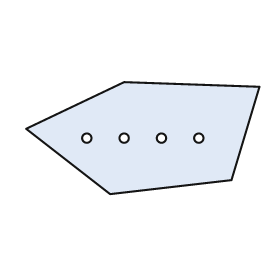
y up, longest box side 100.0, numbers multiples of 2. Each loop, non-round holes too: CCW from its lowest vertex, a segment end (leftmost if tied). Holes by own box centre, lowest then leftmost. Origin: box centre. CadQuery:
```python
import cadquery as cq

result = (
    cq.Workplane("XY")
    .moveTo(-14.0, -24.0)
    .lineTo(38.0, -18.0)
    .lineTo(50.0, 22.0)
    .lineTo(-8.0, 24.0)
    .lineTo(-50.0, 4.0)
    .close()
    .moveTo(-24.0, 0.0)
    .circle(2.0)
    .moveTo(-8.0, 0.0)
    .circle(2.0)
    .moveTo(8.0, 0.0)
    .circle(2.0)
    .moveTo(24.0, 0.0)
    .circle(2.0)
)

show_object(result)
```